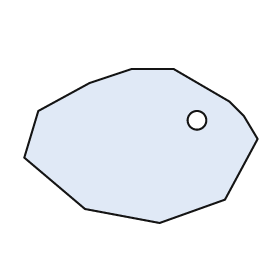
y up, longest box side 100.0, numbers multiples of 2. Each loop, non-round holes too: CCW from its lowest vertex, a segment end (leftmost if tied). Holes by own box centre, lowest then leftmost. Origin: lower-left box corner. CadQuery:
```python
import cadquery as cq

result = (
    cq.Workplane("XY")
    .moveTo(58.0, 0.0)
    .lineTo(86.0, 10.0)
    .lineTo(100.0, 36.0)
    .lineTo(94.0, 46.0)
    .lineTo(88.0, 52.0)
    .lineTo(64.0, 66.0)
    .lineTo(46.0, 66.0)
    .lineTo(28.0, 60.0)
    .lineTo(6.0, 48.0)
    .lineTo(0.0, 28.0)
    .lineTo(26.0, 6.0)
    .close()
    .moveTo(74.0, 44.0)
    .circle(4.0)
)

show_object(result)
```